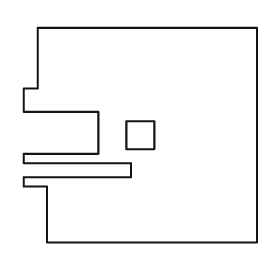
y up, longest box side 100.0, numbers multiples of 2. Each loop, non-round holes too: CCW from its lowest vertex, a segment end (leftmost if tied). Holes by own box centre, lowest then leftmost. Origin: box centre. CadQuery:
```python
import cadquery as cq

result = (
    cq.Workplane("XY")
    .moveTo(-40.0, -46.0)
    .lineTo(50.0, -46.0)
    .lineTo(50.0, 46.0)
    .lineTo(-44.0, 46.0)
    .lineTo(-44.0, 20.0)
    .lineTo(-50.0, 20.0)
    .lineTo(-50.0, 10.0)
    .lineTo(-18.0, 10.0)
    .lineTo(-18.0, -8.0)
    .lineTo(-50.0, -8.0)
    .lineTo(-50.0, -12.0)
    .lineTo(-4.0, -12.0)
    .lineTo(-4.0, -18.0)
    .lineTo(-50.0, -18.0)
    .lineTo(-50.0, -22.0)
    .lineTo(-40.0, -22.0)
    .close()
    .moveTo(-6.0, -6.0)
    .lineTo(6.0, -6.0)
    .lineTo(6.0, 6.0)
    .lineTo(-6.0, 6.0)
    .close()
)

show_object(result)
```